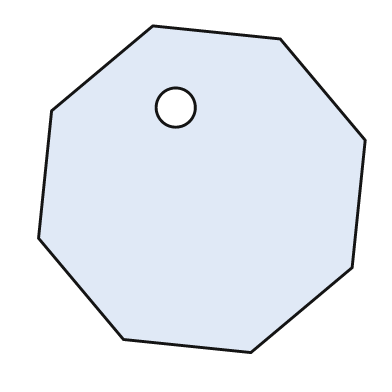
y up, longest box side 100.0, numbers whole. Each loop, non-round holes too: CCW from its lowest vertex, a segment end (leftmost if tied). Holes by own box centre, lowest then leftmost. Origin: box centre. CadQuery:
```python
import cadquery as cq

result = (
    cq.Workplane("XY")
    .moveTo(15.0, -50.0)
    .lineTo(46.0, -24.0)
    .lineTo(50.0, 15.0)
    .lineTo(24.0, 46.0)
    .lineTo(-15.0, 50.0)
    .lineTo(-46.0, 24.0)
    .lineTo(-50.0, -15.0)
    .lineTo(-24.0, -46.0)
    .close()
    .moveTo(-8.0, 25.0)
    .circle(6.0)
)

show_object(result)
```